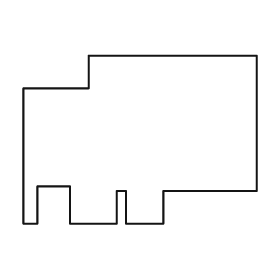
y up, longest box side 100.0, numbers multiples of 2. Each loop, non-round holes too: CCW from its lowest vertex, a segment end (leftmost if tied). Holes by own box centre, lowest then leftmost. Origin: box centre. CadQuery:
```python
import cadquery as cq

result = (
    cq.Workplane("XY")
    .moveTo(-50.0, -36.0)
    .lineTo(-44.0, -36.0)
    .lineTo(-44.0, -20.0)
    .lineTo(-30.0, -20.0)
    .lineTo(-30.0, -36.0)
    .lineTo(-10.0, -36.0)
    .lineTo(-10.0, -22.0)
    .lineTo(-6.0, -22.0)
    .lineTo(-6.0, -36.0)
    .lineTo(10.0, -36.0)
    .lineTo(10.0, -22.0)
    .lineTo(50.0, -22.0)
    .lineTo(50.0, 36.0)
    .lineTo(-22.0, 36.0)
    .lineTo(-22.0, 22.0)
    .lineTo(-50.0, 22.0)
    .close()
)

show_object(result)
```